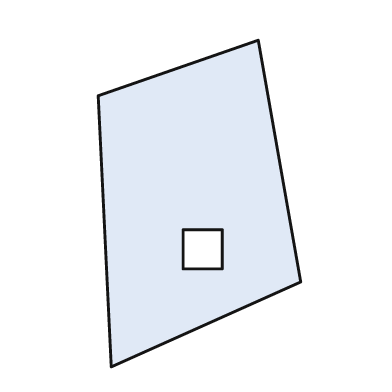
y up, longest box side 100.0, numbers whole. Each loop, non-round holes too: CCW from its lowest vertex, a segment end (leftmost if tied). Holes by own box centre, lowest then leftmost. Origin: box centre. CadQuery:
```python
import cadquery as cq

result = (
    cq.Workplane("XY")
    .moveTo(-27.0, -50.0)
    .lineTo(31.0, -24.0)
    .lineTo(18.0, 50.0)
    .lineTo(-31.0, 33.0)
    .close()
    .moveTo(-5.0, -20.0)
    .lineTo(7.0, -20.0)
    .lineTo(7.0, -8.0)
    .lineTo(-5.0, -8.0)
    .close()
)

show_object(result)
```